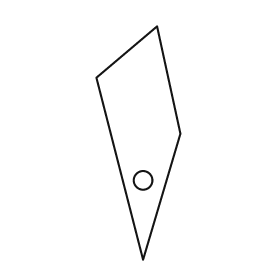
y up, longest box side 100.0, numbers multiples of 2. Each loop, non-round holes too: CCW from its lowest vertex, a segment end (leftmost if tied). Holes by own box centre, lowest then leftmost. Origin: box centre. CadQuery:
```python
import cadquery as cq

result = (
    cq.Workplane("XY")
    .moveTo(2.0, -50.0)
    .lineTo(18.0, 4.0)
    .lineTo(8.0, 50.0)
    .lineTo(-18.0, 28.0)
    .close()
    .moveTo(2.0, -16.0)
    .circle(4.0)
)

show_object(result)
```